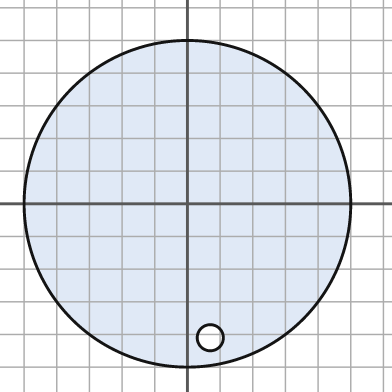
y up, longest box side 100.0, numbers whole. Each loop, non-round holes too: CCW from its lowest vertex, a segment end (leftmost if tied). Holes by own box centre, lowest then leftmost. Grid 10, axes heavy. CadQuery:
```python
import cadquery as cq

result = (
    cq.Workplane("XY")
    .moveTo(0.0, 0.0)
    .circle(50.0)
    .moveTo(7.0, -41.0)
    .circle(4.0)
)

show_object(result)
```